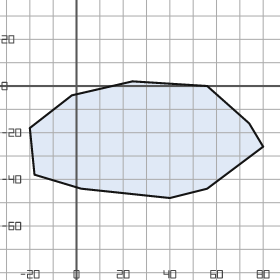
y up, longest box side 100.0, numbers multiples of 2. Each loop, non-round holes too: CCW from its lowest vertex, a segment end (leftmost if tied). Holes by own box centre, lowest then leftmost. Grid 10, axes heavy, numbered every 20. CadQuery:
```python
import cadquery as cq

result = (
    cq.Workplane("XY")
    .moveTo(40.0, -48.0)
    .lineTo(56.0, -44.0)
    .lineTo(80.0, -26.0)
    .lineTo(74.0, -16.0)
    .lineTo(56.0, 0.0)
    .lineTo(24.0, 2.0)
    .lineTo(-2.0, -4.0)
    .lineTo(-20.0, -18.0)
    .lineTo(-18.0, -38.0)
    .lineTo(2.0, -44.0)
    .close()
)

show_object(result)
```